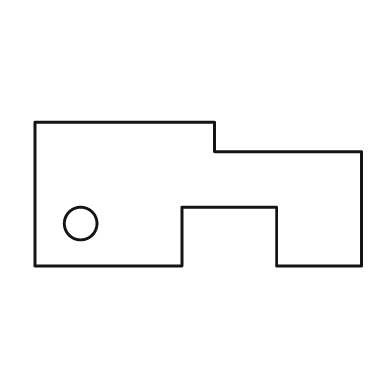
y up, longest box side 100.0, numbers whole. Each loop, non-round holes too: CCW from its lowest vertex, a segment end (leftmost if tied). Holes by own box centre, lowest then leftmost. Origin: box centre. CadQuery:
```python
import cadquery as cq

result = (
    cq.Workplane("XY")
    .moveTo(-50.0, -22.0)
    .lineTo(-5.0, -22.0)
    .lineTo(-5.0, -4.0)
    .lineTo(24.0, -4.0)
    .lineTo(24.0, -22.0)
    .lineTo(50.0, -22.0)
    .lineTo(50.0, 13.0)
    .lineTo(5.0, 13.0)
    .lineTo(5.0, 22.0)
    .lineTo(-50.0, 22.0)
    .close()
    .moveTo(-36.0, -9.0)
    .circle(5.0)
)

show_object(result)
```